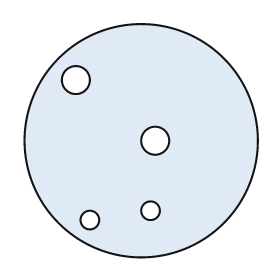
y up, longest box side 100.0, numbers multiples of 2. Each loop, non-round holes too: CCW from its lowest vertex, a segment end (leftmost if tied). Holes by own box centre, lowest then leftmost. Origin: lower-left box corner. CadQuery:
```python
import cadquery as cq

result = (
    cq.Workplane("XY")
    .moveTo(50.0, 50.0)
    .circle(50.0)
    .moveTo(28.0, 16.0)
    .circle(4.0)
    .moveTo(54.0, 20.0)
    .circle(4.0)
    .moveTo(56.0, 50.0)
    .circle(6.0)
    .moveTo(22.0, 76.0)
    .circle(6.0)
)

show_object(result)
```